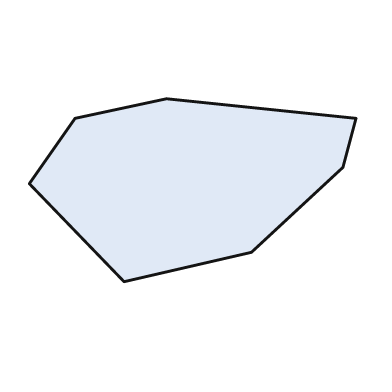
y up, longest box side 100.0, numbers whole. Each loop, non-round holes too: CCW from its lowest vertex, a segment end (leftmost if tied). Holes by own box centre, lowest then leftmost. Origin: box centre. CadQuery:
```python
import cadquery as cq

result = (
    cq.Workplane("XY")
    .moveTo(-21.0, -28.0)
    .lineTo(18.0, -19.0)
    .lineTo(46.0, 7.0)
    .lineTo(50.0, 22.0)
    .lineTo(-8.0, 28.0)
    .lineTo(-36.0, 22.0)
    .lineTo(-50.0, 2.0)
    .close()
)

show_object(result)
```